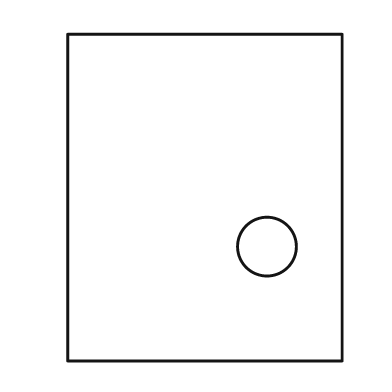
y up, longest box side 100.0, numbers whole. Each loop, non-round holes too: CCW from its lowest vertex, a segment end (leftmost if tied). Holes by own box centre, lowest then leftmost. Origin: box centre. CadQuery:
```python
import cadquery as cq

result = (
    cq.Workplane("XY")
    .moveTo(-42.0, -50.0)
    .lineTo(42.0, -50.0)
    .lineTo(42.0, 50.0)
    .lineTo(-42.0, 50.0)
    .close()
    .moveTo(19.0, -15.0)
    .circle(9.0)
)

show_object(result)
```